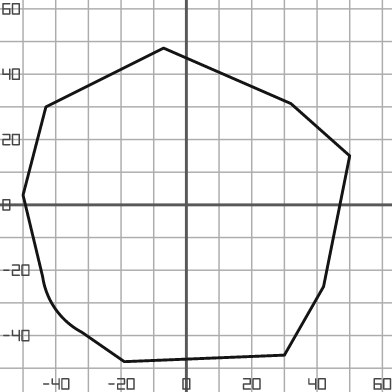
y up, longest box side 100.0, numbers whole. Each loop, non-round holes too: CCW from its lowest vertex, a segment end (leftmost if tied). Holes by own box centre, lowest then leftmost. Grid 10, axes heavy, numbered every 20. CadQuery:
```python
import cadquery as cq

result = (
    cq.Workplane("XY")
    .moveTo(-19.0, -48.0)
    .lineTo(30.0, -46.0)
    .lineTo(42.0, -25.0)
    .lineTo(50.0, 15.0)
    .lineTo(32.0, 31.0)
    .lineTo(-7.0, 48.0)
    .lineTo(-43.0, 30.0)
    .lineTo(-50.0, 3.0)
    .lineTo(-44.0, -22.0)
    .threePointArc((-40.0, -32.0), (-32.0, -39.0))
    .close()
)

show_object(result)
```